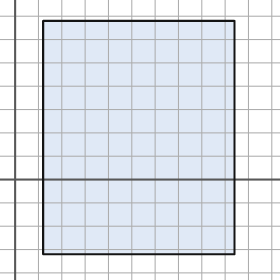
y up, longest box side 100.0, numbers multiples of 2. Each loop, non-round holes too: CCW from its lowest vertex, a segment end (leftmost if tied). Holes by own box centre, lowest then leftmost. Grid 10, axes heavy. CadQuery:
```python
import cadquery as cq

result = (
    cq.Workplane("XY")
    .moveTo(12.0, -32.0)
    .lineTo(94.0, -32.0)
    .lineTo(94.0, 68.0)
    .lineTo(12.0, 68.0)
    .close()
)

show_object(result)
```